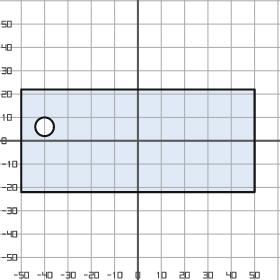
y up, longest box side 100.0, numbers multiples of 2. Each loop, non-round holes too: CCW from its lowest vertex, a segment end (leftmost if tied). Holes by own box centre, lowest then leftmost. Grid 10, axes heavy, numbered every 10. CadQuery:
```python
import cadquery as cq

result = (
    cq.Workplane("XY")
    .moveTo(-50.0, -22.0)
    .lineTo(50.0, -22.0)
    .lineTo(50.0, 22.0)
    .lineTo(-50.0, 22.0)
    .close()
    .moveTo(-40.0, 6.0)
    .circle(4.0)
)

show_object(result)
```